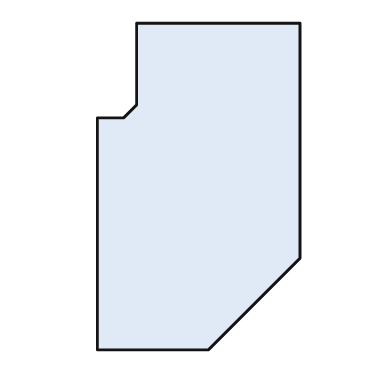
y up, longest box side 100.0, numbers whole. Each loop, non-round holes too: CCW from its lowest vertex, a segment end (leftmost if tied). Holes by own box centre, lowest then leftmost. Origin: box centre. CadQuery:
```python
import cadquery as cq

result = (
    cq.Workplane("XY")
    .moveTo(-31.0, -50.0)
    .lineTo(3.0, -50.0)
    .lineTo(31.0, -22.0)
    .lineTo(31.0, 50.0)
    .lineTo(-19.0, 50.0)
    .lineTo(-19.0, 25.0)
    .lineTo(-23.0, 21.0)
    .lineTo(-31.0, 21.0)
    .close()
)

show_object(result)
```